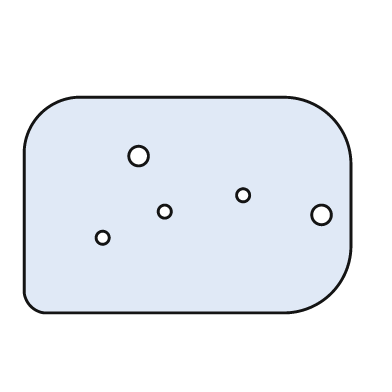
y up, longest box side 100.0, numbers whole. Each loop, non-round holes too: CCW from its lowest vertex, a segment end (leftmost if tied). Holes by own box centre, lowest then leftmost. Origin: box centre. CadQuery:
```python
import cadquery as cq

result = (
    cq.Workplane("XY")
    .moveTo(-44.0, -33.0)
    .lineTo(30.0, -33.0)
    .threePointArc((44.0, -27.0), (50.0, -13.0))
    .lineTo(50.0, 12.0)
    .threePointArc((44.0, 27.0), (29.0, 33.0))
    .lineTo(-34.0, 33.0)
    .threePointArc((-45.0, 28.0), (-50.0, 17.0))
    .lineTo(-50.0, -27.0)
    .threePointArc((-48.0, -31.0), (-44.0, -33.0))
    .close()
    .moveTo(-26.0, -10.0)
    .circle(2.0)
    .moveTo(41.0, -3.0)
    .circle(3.0)
    .moveTo(-7.0, -2.0)
    .circle(2.0)
    .moveTo(17.0, 3.0)
    .circle(2.0)
    .moveTo(-15.0, 15.0)
    .circle(3.0)
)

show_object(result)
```